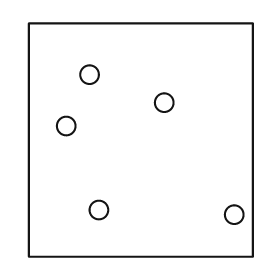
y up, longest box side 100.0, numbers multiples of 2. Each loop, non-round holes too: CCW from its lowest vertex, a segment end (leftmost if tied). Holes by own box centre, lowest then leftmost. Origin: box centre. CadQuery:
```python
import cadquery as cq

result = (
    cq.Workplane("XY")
    .moveTo(-48.0, -50.0)
    .lineTo(48.0, -50.0)
    .lineTo(48.0, 50.0)
    .lineTo(-48.0, 50.0)
    .close()
    .moveTo(40.0, -32.0)
    .circle(4.0)
    .moveTo(-18.0, -30.0)
    .circle(4.0)
    .moveTo(-32.0, 6.0)
    .circle(4.0)
    .moveTo(10.0, 16.0)
    .circle(4.0)
    .moveTo(-22.0, 28.0)
    .circle(4.0)
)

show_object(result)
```